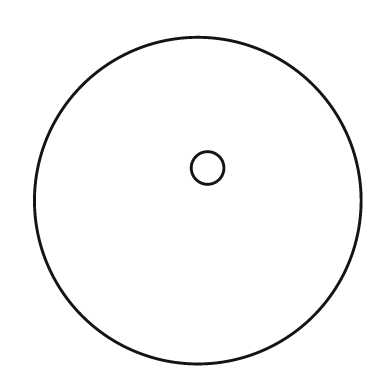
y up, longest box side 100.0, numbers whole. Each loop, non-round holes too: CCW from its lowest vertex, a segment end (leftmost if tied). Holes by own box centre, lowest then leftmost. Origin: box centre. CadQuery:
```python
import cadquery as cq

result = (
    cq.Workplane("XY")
    .moveTo(0.0, 0.0)
    .circle(50.0)
    .moveTo(3.0, 10.0)
    .circle(5.0)
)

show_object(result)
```